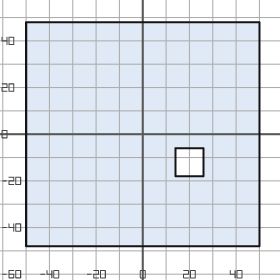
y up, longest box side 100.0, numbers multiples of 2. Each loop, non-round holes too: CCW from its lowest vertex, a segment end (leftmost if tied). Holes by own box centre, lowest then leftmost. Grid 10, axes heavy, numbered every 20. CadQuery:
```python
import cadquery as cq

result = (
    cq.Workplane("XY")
    .moveTo(-50.0, -48.0)
    .lineTo(50.0, -48.0)
    .lineTo(50.0, 48.0)
    .lineTo(-50.0, 48.0)
    .close()
    .moveTo(14.0, -18.0)
    .lineTo(26.0, -18.0)
    .lineTo(26.0, -6.0)
    .lineTo(14.0, -6.0)
    .close()
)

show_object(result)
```